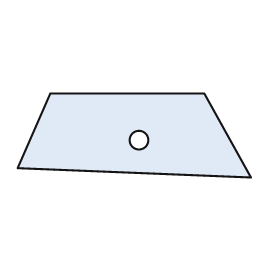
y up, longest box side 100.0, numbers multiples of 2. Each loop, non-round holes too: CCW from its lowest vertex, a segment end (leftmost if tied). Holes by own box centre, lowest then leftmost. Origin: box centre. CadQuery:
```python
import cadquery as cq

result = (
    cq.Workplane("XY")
    .moveTo(50.0, -18.0)
    .lineTo(30.0, 18.0)
    .lineTo(-36.0, 18.0)
    .lineTo(-50.0, -14.0)
    .close()
    .moveTo(2.0, -2.0)
    .circle(4.0)
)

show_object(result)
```